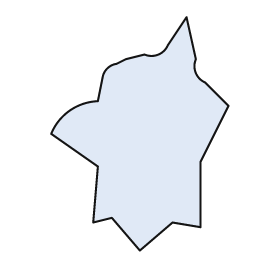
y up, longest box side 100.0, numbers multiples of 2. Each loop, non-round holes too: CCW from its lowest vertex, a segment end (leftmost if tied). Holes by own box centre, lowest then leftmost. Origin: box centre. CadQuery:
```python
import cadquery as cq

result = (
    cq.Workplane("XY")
    .moveTo(0.0, -50.0)
    .lineTo(14.0, -38.0)
    .lineTo(26.0, -40.0)
    .lineTo(26.0, -12.0)
    .lineTo(38.0, 12.0)
    .lineTo(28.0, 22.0)
    .threePointArc((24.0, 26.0), (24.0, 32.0))
    .lineTo(20.0, 50.0)
    .lineTo(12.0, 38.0)
    .threePointArc((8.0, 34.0), (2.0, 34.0))
    .lineTo(-6.0, 32.0)
    .lineTo(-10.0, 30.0)
    .threePointArc((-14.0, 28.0), (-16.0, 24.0))
    .lineTo(-18.0, 14.0)
    .threePointArc((-30.0, 10.0), (-38.0, 0.0))
    .lineTo(-18.0, -14.0)
    .lineTo(-20.0, -38.0)
    .lineTo(-12.0, -36.0)
    .close()
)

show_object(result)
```